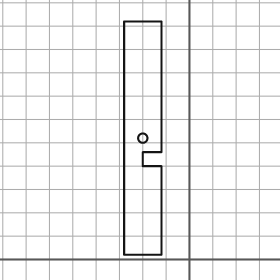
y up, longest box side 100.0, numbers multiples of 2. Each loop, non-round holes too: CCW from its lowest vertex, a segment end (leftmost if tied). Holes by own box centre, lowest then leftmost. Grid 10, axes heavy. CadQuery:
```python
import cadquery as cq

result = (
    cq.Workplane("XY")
    .moveTo(-28.0, 2.0)
    .lineTo(-12.0, 2.0)
    .lineTo(-12.0, 40.0)
    .lineTo(-20.0, 40.0)
    .lineTo(-20.0, 46.0)
    .lineTo(-12.0, 46.0)
    .lineTo(-12.0, 102.0)
    .lineTo(-28.0, 102.0)
    .close()
    .moveTo(-20.0, 52.0)
    .circle(2.0)
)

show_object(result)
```